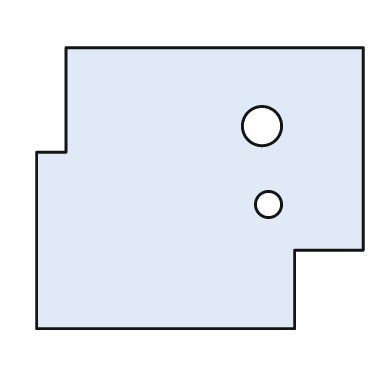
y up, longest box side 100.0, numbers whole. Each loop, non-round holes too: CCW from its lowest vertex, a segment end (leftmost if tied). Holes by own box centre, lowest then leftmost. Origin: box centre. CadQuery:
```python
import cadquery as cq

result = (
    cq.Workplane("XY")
    .moveTo(-50.0, -43.0)
    .lineTo(29.0, -43.0)
    .lineTo(29.0, -19.0)
    .lineTo(50.0, -19.0)
    .lineTo(50.0, 43.0)
    .lineTo(-41.0, 43.0)
    .lineTo(-41.0, 11.0)
    .lineTo(-50.0, 11.0)
    .close()
    .moveTo(21.0, -5.0)
    .circle(4.0)
    .moveTo(19.0, 19.0)
    .circle(6.0)
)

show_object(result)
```